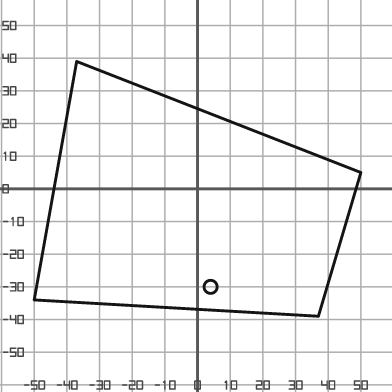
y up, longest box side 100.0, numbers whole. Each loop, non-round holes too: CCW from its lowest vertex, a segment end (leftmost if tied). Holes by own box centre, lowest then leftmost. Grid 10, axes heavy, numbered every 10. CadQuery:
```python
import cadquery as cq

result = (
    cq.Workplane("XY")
    .moveTo(37.0, -39.0)
    .lineTo(50.0, 5.0)
    .lineTo(-37.0, 39.0)
    .lineTo(-50.0, -34.0)
    .close()
    .moveTo(4.0, -30.0)
    .circle(2.0)
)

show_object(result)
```